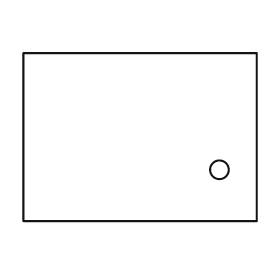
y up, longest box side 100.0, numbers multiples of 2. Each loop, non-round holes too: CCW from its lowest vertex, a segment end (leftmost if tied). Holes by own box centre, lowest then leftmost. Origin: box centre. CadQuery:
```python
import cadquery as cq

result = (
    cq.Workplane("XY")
    .moveTo(-50.0, -36.0)
    .lineTo(50.0, -36.0)
    .lineTo(50.0, 36.0)
    .lineTo(-50.0, 36.0)
    .close()
    .moveTo(34.0, -14.0)
    .circle(4.0)
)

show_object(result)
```